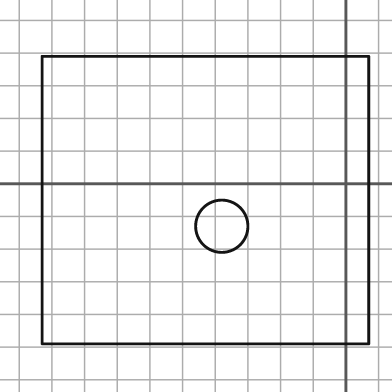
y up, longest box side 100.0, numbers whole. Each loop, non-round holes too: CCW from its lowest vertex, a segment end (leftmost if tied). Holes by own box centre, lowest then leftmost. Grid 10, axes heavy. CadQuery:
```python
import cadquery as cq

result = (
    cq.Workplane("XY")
    .moveTo(-93.0, -49.0)
    .lineTo(7.0, -49.0)
    .lineTo(7.0, 39.0)
    .lineTo(-93.0, 39.0)
    .close()
    .moveTo(-38.0, -13.0)
    .circle(8.0)
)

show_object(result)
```